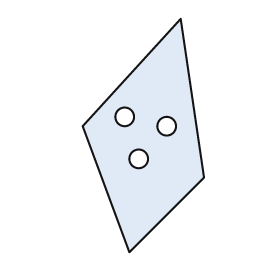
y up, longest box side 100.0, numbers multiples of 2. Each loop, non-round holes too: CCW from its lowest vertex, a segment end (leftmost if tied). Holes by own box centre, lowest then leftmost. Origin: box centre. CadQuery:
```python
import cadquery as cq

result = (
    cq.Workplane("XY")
    .moveTo(-6.0, -50.0)
    .lineTo(26.0, -18.0)
    .lineTo(16.0, 50.0)
    .lineTo(-26.0, 4.0)
    .close()
    .moveTo(-2.0, -10.0)
    .circle(4.0)
    .moveTo(10.0, 4.0)
    .circle(4.0)
    .moveTo(-8.0, 8.0)
    .circle(4.0)
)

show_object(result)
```